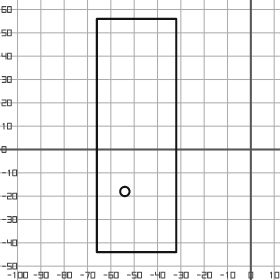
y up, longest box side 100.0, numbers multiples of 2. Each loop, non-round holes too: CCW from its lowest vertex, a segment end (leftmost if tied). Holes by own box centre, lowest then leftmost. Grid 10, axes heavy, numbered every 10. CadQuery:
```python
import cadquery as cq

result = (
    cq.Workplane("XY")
    .moveTo(-66.0, -44.0)
    .lineTo(-32.0, -44.0)
    .lineTo(-32.0, 56.0)
    .lineTo(-66.0, 56.0)
    .close()
    .moveTo(-54.0, -18.0)
    .circle(2.0)
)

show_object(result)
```